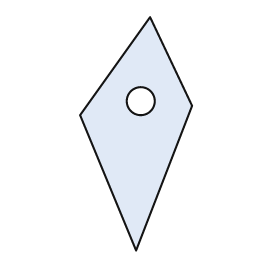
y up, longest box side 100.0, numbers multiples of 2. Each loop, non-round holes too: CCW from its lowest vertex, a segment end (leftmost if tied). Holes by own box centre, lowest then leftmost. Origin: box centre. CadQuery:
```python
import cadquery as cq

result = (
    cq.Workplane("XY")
    .moveTo(0.0, -50.0)
    .lineTo(24.0, 12.0)
    .lineTo(6.0, 50.0)
    .lineTo(-24.0, 8.0)
    .close()
    .moveTo(2.0, 14.0)
    .circle(6.0)
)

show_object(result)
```